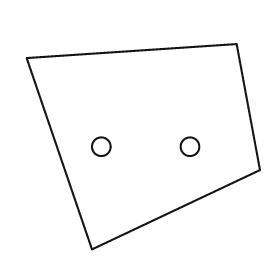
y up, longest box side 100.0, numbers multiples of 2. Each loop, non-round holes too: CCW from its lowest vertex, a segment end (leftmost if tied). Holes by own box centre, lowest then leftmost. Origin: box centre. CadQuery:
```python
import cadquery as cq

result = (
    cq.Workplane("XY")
    .moveTo(-22.0, -44.0)
    .lineTo(50.0, -10.0)
    .lineTo(40.0, 44.0)
    .lineTo(-50.0, 38.0)
    .close()
    .moveTo(-18.0, 0.0)
    .circle(4.0)
    .moveTo(20.0, 0.0)
    .circle(4.0)
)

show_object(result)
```